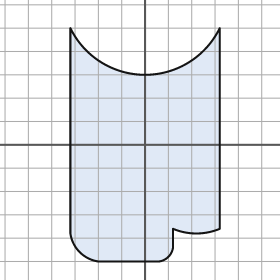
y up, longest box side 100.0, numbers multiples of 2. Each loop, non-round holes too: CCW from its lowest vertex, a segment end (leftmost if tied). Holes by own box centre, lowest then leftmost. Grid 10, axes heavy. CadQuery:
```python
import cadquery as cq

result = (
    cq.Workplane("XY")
    .moveTo(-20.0, -50.0)
    .lineTo(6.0, -50.0)
    .threePointArc((10.0, -48.0), (12.0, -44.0))
    .lineTo(12.0, -36.0)
    .threePointArc((22.0, -38.0), (32.0, -36.0))
    .lineTo(32.0, 50.0)
    .threePointArc((0.0, 30.0), (-32.0, 50.0))
    .lineTo(-32.0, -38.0)
    .threePointArc((-28.0, -46.0), (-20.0, -50.0))
    .close()
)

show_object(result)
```